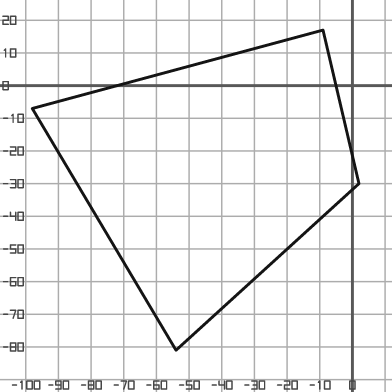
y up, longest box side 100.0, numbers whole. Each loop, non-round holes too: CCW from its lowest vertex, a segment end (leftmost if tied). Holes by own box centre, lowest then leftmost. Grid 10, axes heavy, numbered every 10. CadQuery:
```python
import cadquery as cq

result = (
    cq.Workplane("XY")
    .moveTo(-54.0, -81.0)
    .lineTo(2.0, -30.0)
    .lineTo(-9.0, 17.0)
    .lineTo(-98.0, -7.0)
    .close()
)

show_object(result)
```